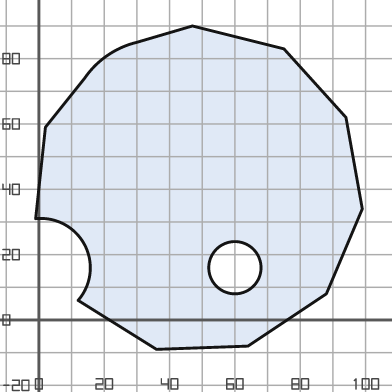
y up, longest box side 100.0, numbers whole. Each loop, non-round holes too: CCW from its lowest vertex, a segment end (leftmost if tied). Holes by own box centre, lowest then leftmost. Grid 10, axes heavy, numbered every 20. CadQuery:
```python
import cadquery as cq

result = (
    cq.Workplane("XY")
    .moveTo(36.0, -9.0)
    .lineTo(64.0, -8.0)
    .lineTo(88.0, 8.0)
    .lineTo(99.0, 34.0)
    .lineTo(94.0, 62.0)
    .lineTo(75.0, 83.0)
    .lineTo(47.0, 90.0)
    .lineTo(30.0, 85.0)
    .threePointArc((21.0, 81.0), (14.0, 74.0))
    .lineTo(2.0, 59.0)
    .lineTo(-1.0, 31.0)
    .threePointArc((14.0, 23.0), (12.0, 6.0))
    .close()
    .moveTo(60.0, 16.0)
    .circle(8.0)
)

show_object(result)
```